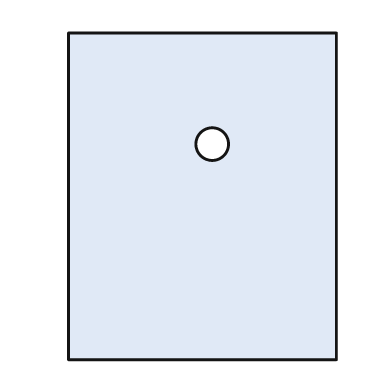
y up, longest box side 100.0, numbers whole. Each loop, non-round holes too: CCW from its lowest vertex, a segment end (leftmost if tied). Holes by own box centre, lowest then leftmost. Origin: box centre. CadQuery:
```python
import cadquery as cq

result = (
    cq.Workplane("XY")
    .moveTo(-41.0, -50.0)
    .lineTo(41.0, -50.0)
    .lineTo(41.0, 50.0)
    .lineTo(-41.0, 50.0)
    .close()
    .moveTo(3.0, 16.0)
    .circle(5.0)
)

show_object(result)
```